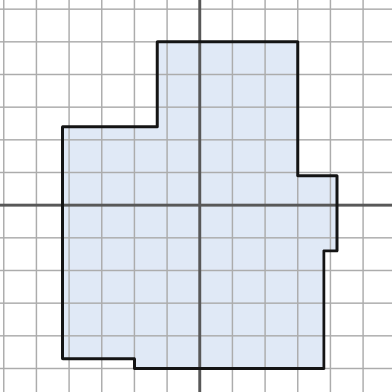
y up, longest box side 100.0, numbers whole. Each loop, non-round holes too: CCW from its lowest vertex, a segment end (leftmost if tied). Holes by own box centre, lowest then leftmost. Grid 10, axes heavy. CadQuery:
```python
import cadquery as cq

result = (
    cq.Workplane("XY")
    .moveTo(-20.0, -50.0)
    .lineTo(38.0, -50.0)
    .lineTo(38.0, -14.0)
    .lineTo(42.0, -14.0)
    .lineTo(42.0, 9.0)
    .lineTo(30.0, 9.0)
    .lineTo(30.0, 50.0)
    .lineTo(-13.0, 50.0)
    .lineTo(-13.0, 24.0)
    .lineTo(-42.0, 24.0)
    .lineTo(-42.0, -47.0)
    .lineTo(-20.0, -47.0)
    .close()
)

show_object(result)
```